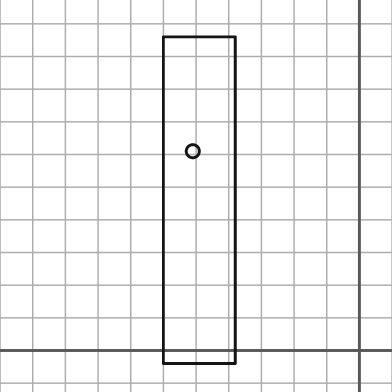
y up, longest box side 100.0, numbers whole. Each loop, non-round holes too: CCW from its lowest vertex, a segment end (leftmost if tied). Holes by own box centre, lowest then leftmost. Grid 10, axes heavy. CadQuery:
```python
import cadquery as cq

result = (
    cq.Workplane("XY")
    .moveTo(-60.0, -4.0)
    .lineTo(-38.0, -4.0)
    .lineTo(-38.0, 96.0)
    .lineTo(-60.0, 96.0)
    .close()
    .moveTo(-51.0, 61.0)
    .circle(2.0)
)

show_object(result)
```